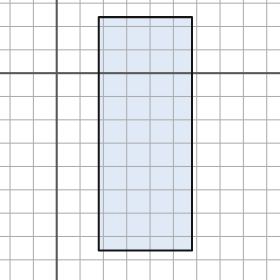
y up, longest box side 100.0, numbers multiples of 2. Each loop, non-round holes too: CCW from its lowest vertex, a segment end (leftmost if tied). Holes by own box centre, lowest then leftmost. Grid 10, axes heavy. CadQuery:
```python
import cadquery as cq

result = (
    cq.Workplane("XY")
    .moveTo(18.0, -76.0)
    .lineTo(58.0, -76.0)
    .lineTo(58.0, 24.0)
    .lineTo(18.0, 24.0)
    .close()
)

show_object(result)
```